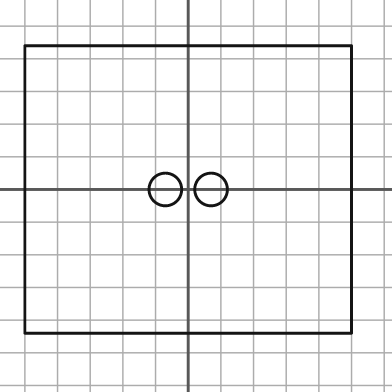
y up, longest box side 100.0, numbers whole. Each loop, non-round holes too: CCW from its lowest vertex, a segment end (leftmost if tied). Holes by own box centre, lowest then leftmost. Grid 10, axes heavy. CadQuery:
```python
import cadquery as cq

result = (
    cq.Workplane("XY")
    .moveTo(-50.0, -44.0)
    .lineTo(50.0, -44.0)
    .lineTo(50.0, 44.0)
    .lineTo(-50.0, 44.0)
    .close()
    .moveTo(-7.0, 0.0)
    .circle(5.0)
    .moveTo(7.0, 0.0)
    .circle(5.0)
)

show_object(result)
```